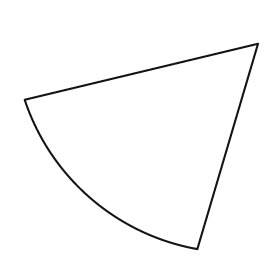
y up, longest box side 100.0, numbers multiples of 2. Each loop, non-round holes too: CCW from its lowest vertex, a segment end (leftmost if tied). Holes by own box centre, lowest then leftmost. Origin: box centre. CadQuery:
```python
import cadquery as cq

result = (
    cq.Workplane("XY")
    .moveTo(24.0, -44.0)
    .lineTo(50.0, 44.0)
    .lineTo(-50.0, 20.0)
    .threePointArc((-22.0, -22.0), (24.0, -44.0))
    .close()
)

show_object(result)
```